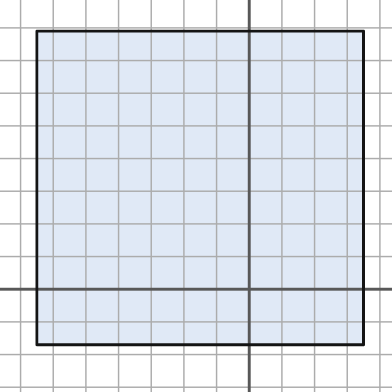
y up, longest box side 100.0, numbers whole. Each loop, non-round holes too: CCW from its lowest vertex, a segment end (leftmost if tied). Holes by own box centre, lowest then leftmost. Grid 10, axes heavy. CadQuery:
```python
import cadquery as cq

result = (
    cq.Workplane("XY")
    .moveTo(-65.0, -17.0)
    .lineTo(35.0, -17.0)
    .lineTo(35.0, 79.0)
    .lineTo(-65.0, 79.0)
    .close()
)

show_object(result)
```